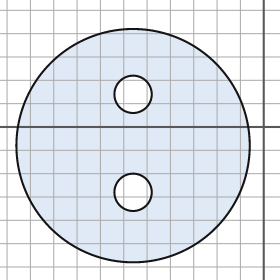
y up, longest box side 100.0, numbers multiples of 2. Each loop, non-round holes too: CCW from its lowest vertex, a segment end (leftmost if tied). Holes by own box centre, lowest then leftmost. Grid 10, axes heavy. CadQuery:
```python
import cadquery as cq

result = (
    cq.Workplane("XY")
    .moveTo(-56.0, -8.0)
    .circle(50.0)
    .moveTo(-56.0, -28.0)
    .circle(8.0)
    .moveTo(-56.0, 14.0)
    .circle(8.0)
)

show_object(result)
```